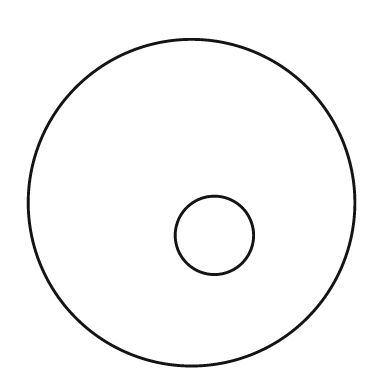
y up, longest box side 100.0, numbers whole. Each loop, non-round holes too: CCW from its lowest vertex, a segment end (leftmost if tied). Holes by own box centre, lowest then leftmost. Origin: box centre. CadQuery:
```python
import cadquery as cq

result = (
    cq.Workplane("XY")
    .moveTo(0.0, 0.0)
    .circle(50.0)
    .moveTo(7.0, -10.0)
    .circle(12.0)
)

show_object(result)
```